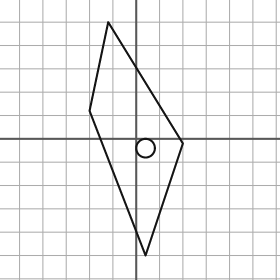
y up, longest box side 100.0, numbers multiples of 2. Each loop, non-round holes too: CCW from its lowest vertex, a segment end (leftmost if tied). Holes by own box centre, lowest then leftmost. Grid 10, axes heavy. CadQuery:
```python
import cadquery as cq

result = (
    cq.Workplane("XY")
    .moveTo(4.0, -50.0)
    .lineTo(20.0, -2.0)
    .lineTo(-12.0, 50.0)
    .lineTo(-20.0, 12.0)
    .close()
    .moveTo(4.0, -4.0)
    .circle(4.0)
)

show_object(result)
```